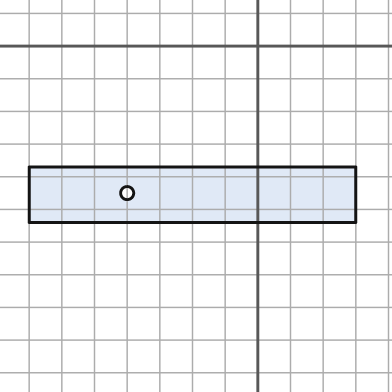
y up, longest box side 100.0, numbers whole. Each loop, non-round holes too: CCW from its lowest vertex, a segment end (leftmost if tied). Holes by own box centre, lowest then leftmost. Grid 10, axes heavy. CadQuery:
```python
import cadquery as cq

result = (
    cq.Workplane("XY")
    .moveTo(-70.0, -54.0)
    .lineTo(30.0, -54.0)
    .lineTo(30.0, -37.0)
    .lineTo(-70.0, -37.0)
    .close()
    .moveTo(-40.0, -45.0)
    .circle(2.0)
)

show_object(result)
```